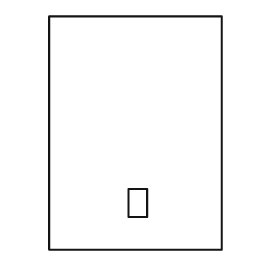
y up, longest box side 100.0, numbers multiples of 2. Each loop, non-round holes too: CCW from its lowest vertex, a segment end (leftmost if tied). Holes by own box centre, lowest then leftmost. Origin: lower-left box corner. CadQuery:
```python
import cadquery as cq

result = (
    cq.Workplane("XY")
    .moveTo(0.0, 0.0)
    .lineTo(74.0, 0.0)
    .lineTo(74.0, 100.0)
    .lineTo(0.0, 100.0)
    .close()
    .moveTo(34.0, 14.0)
    .lineTo(42.0, 14.0)
    .lineTo(42.0, 26.0)
    .lineTo(34.0, 26.0)
    .close()
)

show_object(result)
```